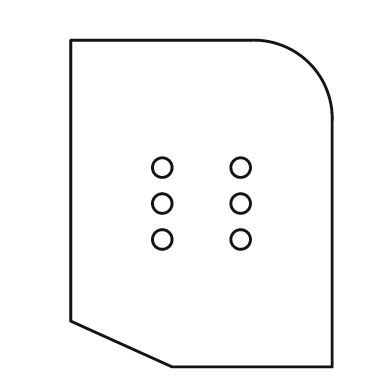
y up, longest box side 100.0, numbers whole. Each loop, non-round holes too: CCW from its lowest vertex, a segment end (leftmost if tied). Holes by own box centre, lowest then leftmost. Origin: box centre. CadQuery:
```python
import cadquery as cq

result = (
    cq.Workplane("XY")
    .moveTo(-9.0, -50.0)
    .lineTo(40.0, -50.0)
    .lineTo(40.0, 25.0)
    .threePointArc((33.0, 43.0), (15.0, 50.0))
    .lineTo(-40.0, 50.0)
    .lineTo(-40.0, -36.0)
    .close()
    .moveTo(-12.0, -11.0)
    .circle(3.0)
    .moveTo(12.0, -11.0)
    .circle(3.0)
    .moveTo(-12.0, 0.0)
    .circle(3.0)
    .moveTo(12.0, 0.0)
    .circle(3.0)
    .moveTo(-12.0, 11.0)
    .circle(3.0)
    .moveTo(12.0, 11.0)
    .circle(3.0)
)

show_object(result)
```